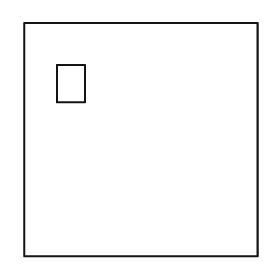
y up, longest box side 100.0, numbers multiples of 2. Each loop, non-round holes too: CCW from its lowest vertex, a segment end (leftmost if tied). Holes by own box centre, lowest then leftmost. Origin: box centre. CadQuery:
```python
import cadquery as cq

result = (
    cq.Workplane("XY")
    .moveTo(-50.0, -50.0)
    .lineTo(50.0, -50.0)
    .lineTo(50.0, 50.0)
    .lineTo(-50.0, 50.0)
    .close()
    .moveTo(-36.0, 16.0)
    .lineTo(-24.0, 16.0)
    .lineTo(-24.0, 32.0)
    .lineTo(-36.0, 32.0)
    .close()
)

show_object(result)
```